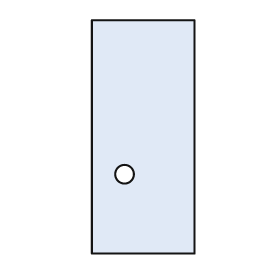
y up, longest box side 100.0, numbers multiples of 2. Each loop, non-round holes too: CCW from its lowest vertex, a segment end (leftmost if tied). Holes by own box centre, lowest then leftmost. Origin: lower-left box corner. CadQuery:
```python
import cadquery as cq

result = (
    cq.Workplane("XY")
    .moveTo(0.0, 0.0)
    .lineTo(44.0, 0.0)
    .lineTo(44.0, 100.0)
    .lineTo(0.0, 100.0)
    .close()
    .moveTo(14.0, 34.0)
    .circle(4.0)
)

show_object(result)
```